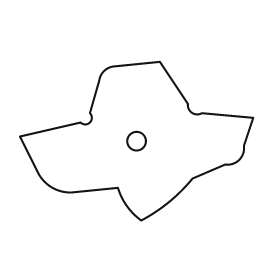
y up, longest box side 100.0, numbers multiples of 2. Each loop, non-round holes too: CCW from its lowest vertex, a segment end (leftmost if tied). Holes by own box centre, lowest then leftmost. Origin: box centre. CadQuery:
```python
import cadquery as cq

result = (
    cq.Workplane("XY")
    .moveTo(2.0, -34.0)
    .threePointArc((14.0, -26.0), (24.0, -16.0))
    .lineTo(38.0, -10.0)
    .threePointArc((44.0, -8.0), (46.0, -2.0))
    .lineTo(50.0, 10.0)
    .lineTo(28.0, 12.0)
    .threePointArc((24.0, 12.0), (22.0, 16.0))
    .lineTo(10.0, 34.0)
    .lineTo(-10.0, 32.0)
    .threePointArc((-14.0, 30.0), (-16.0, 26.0))
    .lineTo(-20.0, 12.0)
    .threePointArc((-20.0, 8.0), (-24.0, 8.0))
    .lineTo(-50.0, 2.0)
    .lineTo(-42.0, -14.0)
    .threePointArc((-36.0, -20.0), (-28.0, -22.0))
    .lineTo(-8.0, -20.0)
    .threePointArc((-4.0, -28.0), (2.0, -34.0))
    .close()
    .moveTo(0.0, 0.0)
    .circle(4.0)
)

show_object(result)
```